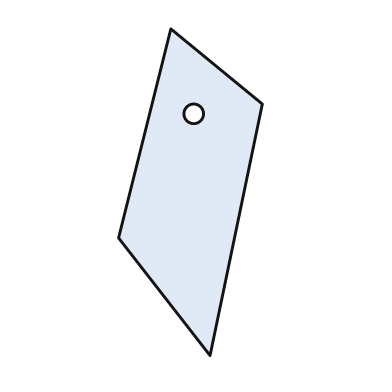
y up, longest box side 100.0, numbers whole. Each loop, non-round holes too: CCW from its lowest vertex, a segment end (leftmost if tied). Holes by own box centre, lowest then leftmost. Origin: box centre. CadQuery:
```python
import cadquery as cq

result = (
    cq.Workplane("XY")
    .moveTo(6.0, -50.0)
    .lineTo(22.0, 27.0)
    .lineTo(-6.0, 50.0)
    .lineTo(-22.0, -14.0)
    .close()
    .moveTo(1.0, 24.0)
    .circle(3.0)
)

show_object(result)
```